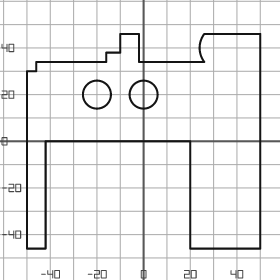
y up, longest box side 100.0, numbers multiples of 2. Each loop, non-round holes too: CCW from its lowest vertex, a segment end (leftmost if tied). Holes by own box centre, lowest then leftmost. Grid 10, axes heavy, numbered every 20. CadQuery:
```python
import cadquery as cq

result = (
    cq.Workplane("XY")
    .moveTo(-50.0, -46.0)
    .lineTo(-42.0, -46.0)
    .lineTo(-42.0, 0.0)
    .lineTo(20.0, 0.0)
    .lineTo(20.0, -46.0)
    .lineTo(50.0, -46.0)
    .lineTo(50.0, 46.0)
    .lineTo(26.0, 46.0)
    .threePointArc((24.0, 40.0), (26.0, 34.0))
    .lineTo(-2.0, 34.0)
    .lineTo(-2.0, 46.0)
    .lineTo(-10.0, 46.0)
    .lineTo(-10.0, 38.0)
    .lineTo(-16.0, 38.0)
    .lineTo(-16.0, 34.0)
    .lineTo(-46.0, 34.0)
    .lineTo(-46.0, 30.0)
    .lineTo(-50.0, 30.0)
    .close()
    .moveTo(-20.0, 20.0)
    .circle(6.0)
    .moveTo(0.0, 20.0)
    .circle(6.0)
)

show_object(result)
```